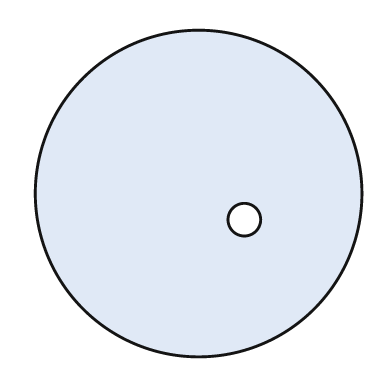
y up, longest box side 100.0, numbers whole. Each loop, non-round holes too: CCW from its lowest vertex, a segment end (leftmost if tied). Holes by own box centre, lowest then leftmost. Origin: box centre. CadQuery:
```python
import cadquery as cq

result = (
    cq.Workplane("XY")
    .moveTo(0.0, 0.0)
    .circle(50.0)
    .moveTo(14.0, -8.0)
    .circle(5.0)
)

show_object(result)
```